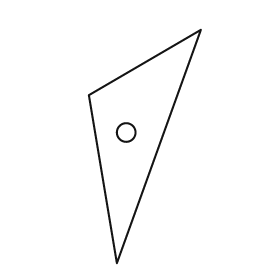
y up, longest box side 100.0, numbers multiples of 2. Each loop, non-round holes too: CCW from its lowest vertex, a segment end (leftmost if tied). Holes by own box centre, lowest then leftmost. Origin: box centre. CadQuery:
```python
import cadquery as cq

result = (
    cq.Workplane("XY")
    .moveTo(-12.0, -50.0)
    .lineTo(24.0, 50.0)
    .lineTo(-24.0, 22.0)
    .close()
    .moveTo(-8.0, 6.0)
    .circle(4.0)
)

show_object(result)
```